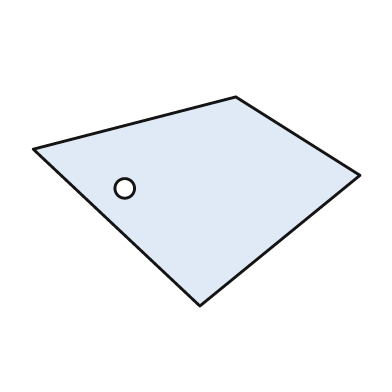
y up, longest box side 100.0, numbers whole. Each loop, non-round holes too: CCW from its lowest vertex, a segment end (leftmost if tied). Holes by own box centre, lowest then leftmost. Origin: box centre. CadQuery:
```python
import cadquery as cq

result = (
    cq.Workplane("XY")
    .moveTo(1.0, -32.0)
    .lineTo(50.0, 8.0)
    .lineTo(12.0, 32.0)
    .lineTo(-50.0, 16.0)
    .close()
    .moveTo(-22.0, 4.0)
    .circle(3.0)
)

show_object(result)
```